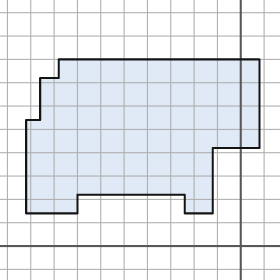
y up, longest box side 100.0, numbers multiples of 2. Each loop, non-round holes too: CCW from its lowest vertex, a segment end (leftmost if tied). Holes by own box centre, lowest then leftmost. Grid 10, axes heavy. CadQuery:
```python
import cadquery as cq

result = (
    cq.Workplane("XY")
    .moveTo(-92.0, 14.0)
    .lineTo(-70.0, 14.0)
    .lineTo(-70.0, 22.0)
    .lineTo(-24.0, 22.0)
    .lineTo(-24.0, 14.0)
    .lineTo(-12.0, 14.0)
    .lineTo(-12.0, 42.0)
    .lineTo(8.0, 42.0)
    .lineTo(8.0, 80.0)
    .lineTo(-78.0, 80.0)
    .lineTo(-78.0, 72.0)
    .lineTo(-86.0, 72.0)
    .lineTo(-86.0, 54.0)
    .lineTo(-92.0, 54.0)
    .close()
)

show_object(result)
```